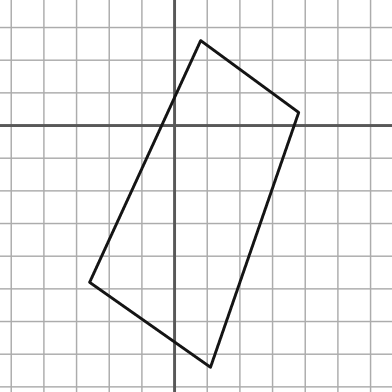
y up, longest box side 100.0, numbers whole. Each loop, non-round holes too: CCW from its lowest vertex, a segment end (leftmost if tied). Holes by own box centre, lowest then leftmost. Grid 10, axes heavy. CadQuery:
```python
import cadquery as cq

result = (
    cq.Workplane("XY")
    .moveTo(11.0, -74.0)
    .lineTo(38.0, 4.0)
    .lineTo(8.0, 26.0)
    .lineTo(-26.0, -48.0)
    .close()
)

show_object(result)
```